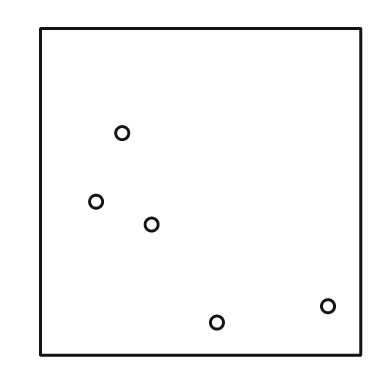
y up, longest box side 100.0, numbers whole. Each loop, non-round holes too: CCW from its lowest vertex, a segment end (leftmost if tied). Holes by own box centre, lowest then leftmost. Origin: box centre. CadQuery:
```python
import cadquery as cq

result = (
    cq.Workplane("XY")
    .moveTo(-49.0, -50.0)
    .lineTo(49.0, -50.0)
    .lineTo(49.0, 50.0)
    .lineTo(-49.0, 50.0)
    .close()
    .moveTo(5.0, -40.0)
    .circle(2.0)
    .moveTo(39.0, -35.0)
    .circle(2.0)
    .moveTo(-15.0, -10.0)
    .circle(2.0)
    .moveTo(-32.0, -3.0)
    .circle(2.0)
    .moveTo(-24.0, 18.0)
    .circle(2.0)
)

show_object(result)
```